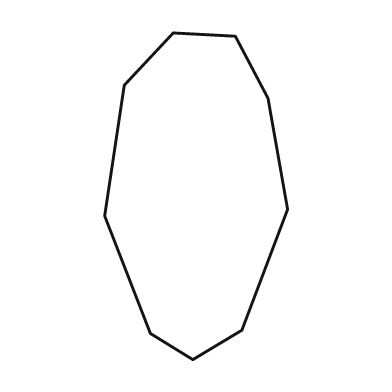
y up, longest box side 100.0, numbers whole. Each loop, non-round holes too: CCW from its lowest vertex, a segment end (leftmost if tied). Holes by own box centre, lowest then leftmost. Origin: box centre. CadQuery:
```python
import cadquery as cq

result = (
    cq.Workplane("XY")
    .moveTo(-1.0, -50.0)
    .lineTo(14.0, -41.0)
    .lineTo(28.0, -4.0)
    .lineTo(22.0, 30.0)
    .lineTo(12.0, 49.0)
    .lineTo(-7.0, 50.0)
    .lineTo(-22.0, 34.0)
    .lineTo(-28.0, -6.0)
    .lineTo(-14.0, -42.0)
    .close()
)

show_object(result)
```